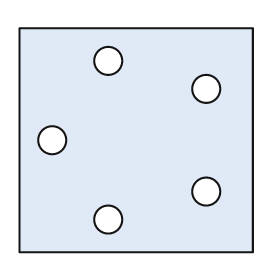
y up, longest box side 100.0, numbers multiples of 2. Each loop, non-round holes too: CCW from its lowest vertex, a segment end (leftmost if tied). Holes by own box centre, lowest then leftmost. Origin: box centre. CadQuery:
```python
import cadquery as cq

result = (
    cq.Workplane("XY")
    .moveTo(-50.0, -48.0)
    .lineTo(50.0, -48.0)
    .lineTo(50.0, 48.0)
    .lineTo(-50.0, 48.0)
    .close()
    .moveTo(-12.0, -34.0)
    .circle(6.0)
    .moveTo(30.0, -22.0)
    .circle(6.0)
    .moveTo(-36.0, 0.0)
    .circle(6.0)
    .moveTo(30.0, 22.0)
    .circle(6.0)
    .moveTo(-12.0, 34.0)
    .circle(6.0)
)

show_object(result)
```